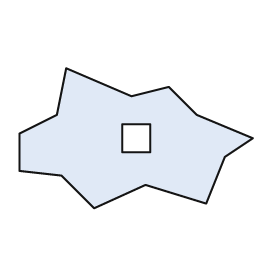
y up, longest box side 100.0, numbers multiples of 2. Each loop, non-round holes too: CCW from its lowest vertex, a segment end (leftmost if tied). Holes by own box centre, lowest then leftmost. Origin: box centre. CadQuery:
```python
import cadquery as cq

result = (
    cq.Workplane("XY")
    .moveTo(-18.0, -30.0)
    .lineTo(4.0, -20.0)
    .lineTo(30.0, -28.0)
    .lineTo(38.0, -8.0)
    .lineTo(50.0, 0.0)
    .lineTo(26.0, 10.0)
    .lineTo(14.0, 22.0)
    .lineTo(-2.0, 18.0)
    .lineTo(-30.0, 30.0)
    .lineTo(-34.0, 10.0)
    .lineTo(-50.0, 2.0)
    .lineTo(-50.0, -14.0)
    .lineTo(-32.0, -16.0)
    .close()
    .moveTo(-6.0, -6.0)
    .lineTo(6.0, -6.0)
    .lineTo(6.0, 6.0)
    .lineTo(-6.0, 6.0)
    .close()
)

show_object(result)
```